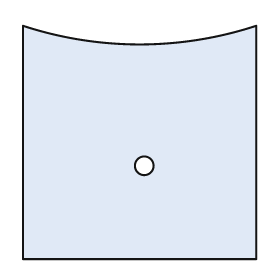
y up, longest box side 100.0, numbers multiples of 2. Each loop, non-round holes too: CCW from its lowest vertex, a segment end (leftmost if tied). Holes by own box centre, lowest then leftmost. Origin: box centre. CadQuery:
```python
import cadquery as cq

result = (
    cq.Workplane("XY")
    .moveTo(-50.0, -50.0)
    .lineTo(50.0, -50.0)
    .lineTo(50.0, 50.0)
    .threePointArc((0.0, 42.0), (-50.0, 50.0))
    .close()
    .moveTo(2.0, -10.0)
    .circle(4.0)
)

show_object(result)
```